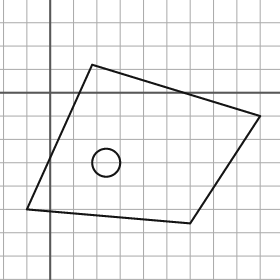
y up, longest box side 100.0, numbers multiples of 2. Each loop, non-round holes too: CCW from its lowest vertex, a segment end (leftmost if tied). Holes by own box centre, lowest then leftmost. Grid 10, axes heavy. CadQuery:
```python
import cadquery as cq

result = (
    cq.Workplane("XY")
    .moveTo(60.0, -56.0)
    .lineTo(90.0, -10.0)
    .lineTo(18.0, 12.0)
    .lineTo(-10.0, -50.0)
    .close()
    .moveTo(24.0, -30.0)
    .circle(6.0)
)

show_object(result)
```